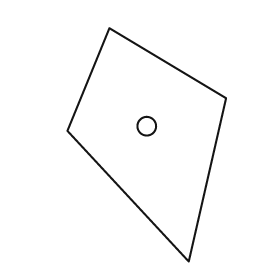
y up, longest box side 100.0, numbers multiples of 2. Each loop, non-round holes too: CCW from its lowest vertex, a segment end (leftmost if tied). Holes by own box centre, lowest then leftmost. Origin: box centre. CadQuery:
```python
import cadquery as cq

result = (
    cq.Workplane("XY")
    .moveTo(18.0, -50.0)
    .lineTo(34.0, 20.0)
    .lineTo(-16.0, 50.0)
    .lineTo(-34.0, 6.0)
    .close()
    .moveTo(0.0, 8.0)
    .circle(4.0)
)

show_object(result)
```